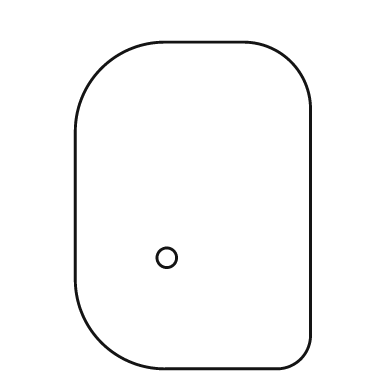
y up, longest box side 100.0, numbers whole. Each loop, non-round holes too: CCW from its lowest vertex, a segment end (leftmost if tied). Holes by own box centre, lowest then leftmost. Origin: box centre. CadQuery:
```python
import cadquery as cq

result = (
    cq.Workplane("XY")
    .moveTo(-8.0, -50.0)
    .lineTo(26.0, -50.0)
    .threePointArc((33.0, -47.0), (36.0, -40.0))
    .lineTo(36.0, 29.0)
    .threePointArc((30.0, 44.0), (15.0, 50.0))
    .lineTo(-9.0, 50.0)
    .threePointArc((-28.0, 42.0), (-36.0, 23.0))
    .lineTo(-36.0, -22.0)
    .threePointArc((-28.0, -42.0), (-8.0, -50.0))
    .close()
    .moveTo(-8.0, -16.0)
    .circle(3.0)
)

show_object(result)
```